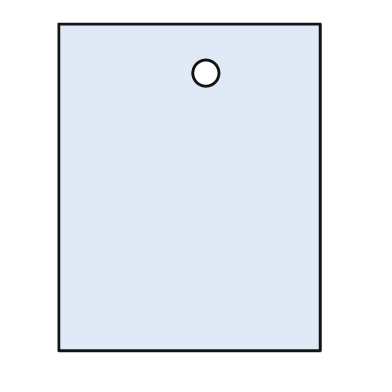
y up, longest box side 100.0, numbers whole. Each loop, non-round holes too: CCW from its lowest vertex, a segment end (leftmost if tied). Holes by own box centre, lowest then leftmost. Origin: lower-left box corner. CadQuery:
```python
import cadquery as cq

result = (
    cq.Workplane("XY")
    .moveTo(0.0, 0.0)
    .lineTo(80.0, 0.0)
    .lineTo(80.0, 100.0)
    .lineTo(0.0, 100.0)
    .close()
    .moveTo(45.0, 85.0)
    .circle(4.0)
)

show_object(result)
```